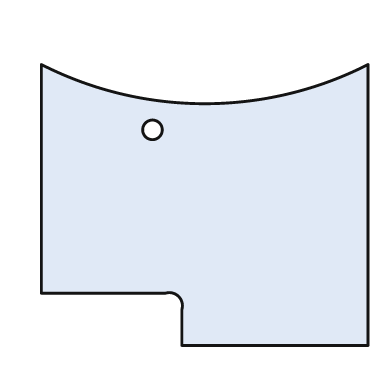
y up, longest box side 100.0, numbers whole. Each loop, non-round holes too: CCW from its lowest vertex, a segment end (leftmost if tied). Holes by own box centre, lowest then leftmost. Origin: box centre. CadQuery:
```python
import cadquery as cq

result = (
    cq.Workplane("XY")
    .moveTo(-7.0, -43.0)
    .lineTo(50.0, -43.0)
    .lineTo(50.0, 43.0)
    .threePointArc((0.0, 31.0), (-50.0, 43.0))
    .lineTo(-50.0, -27.0)
    .lineTo(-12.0, -27.0)
    .threePointArc((-8.0, -28.0), (-7.0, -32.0))
    .close()
    .moveTo(-16.0, 23.0)
    .circle(3.0)
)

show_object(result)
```